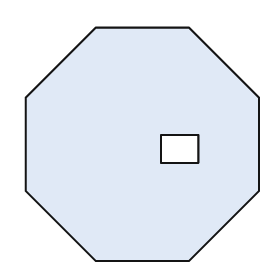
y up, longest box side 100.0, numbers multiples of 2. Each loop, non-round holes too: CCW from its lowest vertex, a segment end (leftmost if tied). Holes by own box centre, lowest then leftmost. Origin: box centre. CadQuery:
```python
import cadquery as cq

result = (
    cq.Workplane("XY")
    .moveTo(-20.0, -50.0)
    .lineTo(20.0, -50.0)
    .lineTo(50.0, -20.0)
    .lineTo(50.0, 20.0)
    .lineTo(20.0, 50.0)
    .lineTo(-20.0, 50.0)
    .lineTo(-50.0, 20.0)
    .lineTo(-50.0, -20.0)
    .close()
    .moveTo(8.0, -8.0)
    .lineTo(24.0, -8.0)
    .lineTo(24.0, 4.0)
    .lineTo(8.0, 4.0)
    .close()
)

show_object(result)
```